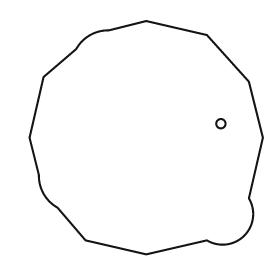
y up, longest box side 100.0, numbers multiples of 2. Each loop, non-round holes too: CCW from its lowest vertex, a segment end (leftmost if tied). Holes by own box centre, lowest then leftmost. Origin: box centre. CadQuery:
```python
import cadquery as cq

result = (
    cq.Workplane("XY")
    .moveTo(0.0, -50.0)
    .lineTo(26.0, -44.0)
    .threePointArc((42.0, -42.0), (44.0, -26.0))
    .lineTo(50.0, 0.0)
    .lineTo(44.0, 24.0)
    .lineTo(26.0, 44.0)
    .lineTo(0.0, 50.0)
    .lineTo(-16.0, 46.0)
    .threePointArc((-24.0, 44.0), (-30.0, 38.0))
    .lineTo(-44.0, 26.0)
    .lineTo(-50.0, 0.0)
    .lineTo(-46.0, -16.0)
    .threePointArc((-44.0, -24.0), (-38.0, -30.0))
    .lineTo(-26.0, -44.0)
    .close()
    .moveTo(32.0, 6.0)
    .circle(2.0)
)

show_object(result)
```